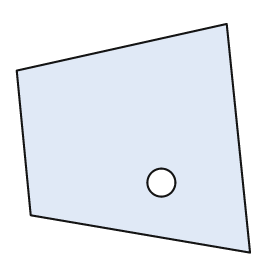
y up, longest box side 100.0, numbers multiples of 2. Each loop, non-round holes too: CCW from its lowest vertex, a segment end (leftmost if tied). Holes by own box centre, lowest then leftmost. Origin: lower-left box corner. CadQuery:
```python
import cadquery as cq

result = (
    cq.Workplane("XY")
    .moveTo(100.0, 0.0)
    .lineTo(90.0, 98.0)
    .lineTo(0.0, 78.0)
    .lineTo(6.0, 16.0)
    .close()
    .moveTo(62.0, 30.0)
    .circle(6.0)
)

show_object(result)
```